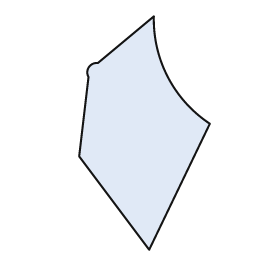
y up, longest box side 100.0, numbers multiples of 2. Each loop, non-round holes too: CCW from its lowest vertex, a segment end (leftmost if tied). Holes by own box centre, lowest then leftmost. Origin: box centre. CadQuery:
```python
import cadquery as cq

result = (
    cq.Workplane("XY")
    .moveTo(2.0, -50.0)
    .lineTo(28.0, 4.0)
    .threePointArc((10.0, 24.0), (4.0, 50.0))
    .lineTo(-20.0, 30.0)
    .threePointArc((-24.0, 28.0), (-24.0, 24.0))
    .lineTo(-28.0, -10.0)
    .close()
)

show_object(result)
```